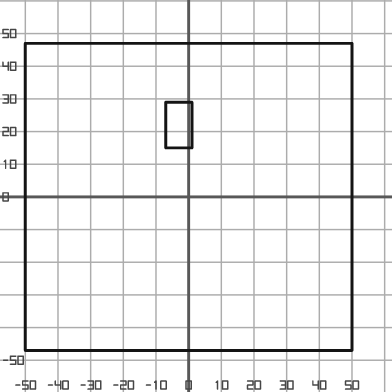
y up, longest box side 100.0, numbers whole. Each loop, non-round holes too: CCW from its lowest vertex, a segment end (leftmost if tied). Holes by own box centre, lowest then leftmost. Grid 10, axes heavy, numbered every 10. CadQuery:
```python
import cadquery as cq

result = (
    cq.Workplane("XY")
    .moveTo(-50.0, -47.0)
    .lineTo(50.0, -47.0)
    .lineTo(50.0, 47.0)
    .lineTo(-50.0, 47.0)
    .close()
    .moveTo(-7.0, 15.0)
    .lineTo(1.0, 15.0)
    .lineTo(1.0, 29.0)
    .lineTo(-7.0, 29.0)
    .close()
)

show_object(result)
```